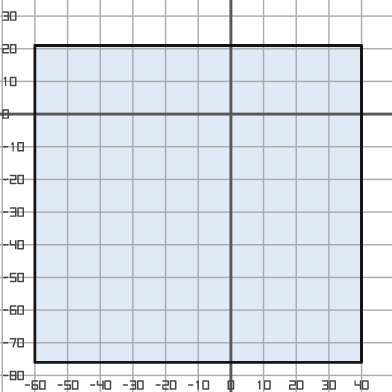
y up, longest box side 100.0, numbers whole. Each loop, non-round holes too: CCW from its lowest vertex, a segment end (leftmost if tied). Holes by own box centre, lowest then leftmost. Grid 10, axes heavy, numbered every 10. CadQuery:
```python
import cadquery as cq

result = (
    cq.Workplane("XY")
    .moveTo(-60.0, -76.0)
    .lineTo(40.0, -76.0)
    .lineTo(40.0, 21.0)
    .lineTo(-60.0, 21.0)
    .close()
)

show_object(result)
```